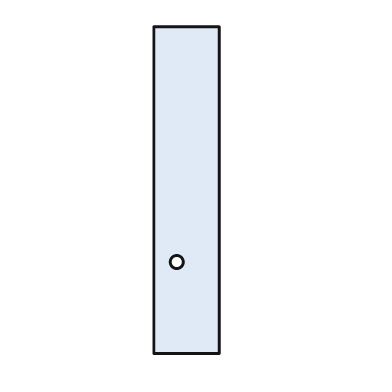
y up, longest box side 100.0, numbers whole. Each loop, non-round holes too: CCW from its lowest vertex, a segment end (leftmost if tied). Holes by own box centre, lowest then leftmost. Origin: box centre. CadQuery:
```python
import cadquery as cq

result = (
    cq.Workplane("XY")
    .moveTo(-10.0, -50.0)
    .lineTo(10.0, -50.0)
    .lineTo(10.0, 50.0)
    .lineTo(-10.0, 50.0)
    .close()
    .moveTo(-3.0, -22.0)
    .circle(2.0)
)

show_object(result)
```